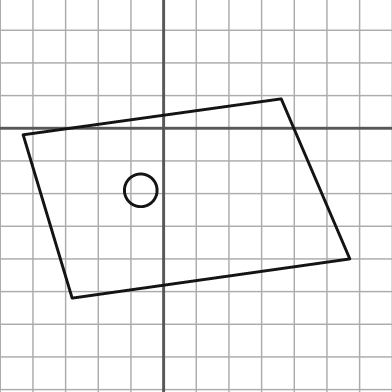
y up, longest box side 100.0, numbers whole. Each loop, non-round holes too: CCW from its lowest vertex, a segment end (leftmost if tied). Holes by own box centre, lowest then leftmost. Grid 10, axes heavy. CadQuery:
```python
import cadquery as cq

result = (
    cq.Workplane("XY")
    .moveTo(-28.0, -52.0)
    .lineTo(57.0, -40.0)
    .lineTo(36.0, 9.0)
    .lineTo(-43.0, -2.0)
    .close()
    .moveTo(-7.0, -19.0)
    .circle(5.0)
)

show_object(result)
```